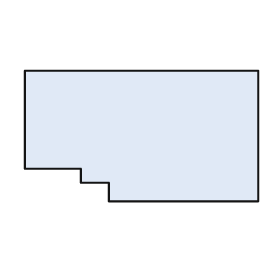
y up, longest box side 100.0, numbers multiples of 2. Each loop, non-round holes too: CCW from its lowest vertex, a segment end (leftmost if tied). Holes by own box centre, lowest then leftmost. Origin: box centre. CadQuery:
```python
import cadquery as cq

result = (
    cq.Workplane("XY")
    .moveTo(-14.0, -28.0)
    .lineTo(50.0, -28.0)
    .lineTo(50.0, 28.0)
    .lineTo(-50.0, 28.0)
    .lineTo(-50.0, -14.0)
    .lineTo(-26.0, -14.0)
    .lineTo(-26.0, -20.0)
    .lineTo(-14.0, -20.0)
    .close()
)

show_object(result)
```